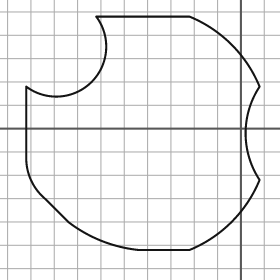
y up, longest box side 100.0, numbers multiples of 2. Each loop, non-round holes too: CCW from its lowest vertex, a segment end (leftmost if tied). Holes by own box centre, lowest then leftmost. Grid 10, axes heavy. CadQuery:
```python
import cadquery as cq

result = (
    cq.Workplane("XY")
    .moveTo(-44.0, -52.0)
    .lineTo(-22.0, -52.0)
    .threePointArc((-4.0, -40.0), (8.0, -22.0))
    .threePointArc((2.0, -2.0), (8.0, 18.0))
    .threePointArc((-4.0, 36.0), (-22.0, 48.0))
    .lineTo(-62.0, 48.0)
    .threePointArc((-64.0, 20.0), (-92.0, 18.0))
    .lineTo(-92.0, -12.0)
    .threePointArc((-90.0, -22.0), (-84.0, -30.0))
    .lineTo(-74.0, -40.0)
    .threePointArc((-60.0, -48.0), (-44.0, -52.0))
    .close()
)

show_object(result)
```